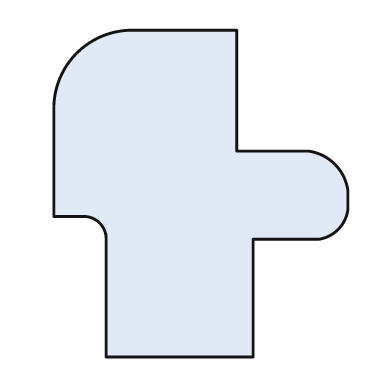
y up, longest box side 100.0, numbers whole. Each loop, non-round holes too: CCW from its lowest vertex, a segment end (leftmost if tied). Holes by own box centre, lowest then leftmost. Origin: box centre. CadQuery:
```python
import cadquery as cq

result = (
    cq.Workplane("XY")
    .moveTo(-29.0, -50.0)
    .lineTo(16.0, -50.0)
    .lineTo(16.0, -14.0)
    .lineTo(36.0, -14.0)
    .threePointArc((42.0, -11.0), (45.0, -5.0))
    .lineTo(45.0, 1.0)
    .threePointArc((41.0, 9.0), (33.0, 13.0))
    .lineTo(11.0, 13.0)
    .lineTo(11.0, 50.0)
    .lineTo(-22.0, 50.0)
    .threePointArc((-38.0, 43.0), (-45.0, 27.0))
    .lineTo(-45.0, -7.0)
    .lineTo(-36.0, -7.0)
    .threePointArc((-31.0, -9.0), (-29.0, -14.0))
    .close()
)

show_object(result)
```